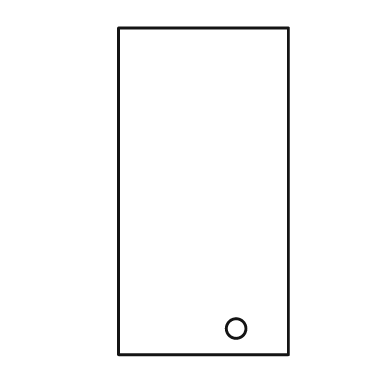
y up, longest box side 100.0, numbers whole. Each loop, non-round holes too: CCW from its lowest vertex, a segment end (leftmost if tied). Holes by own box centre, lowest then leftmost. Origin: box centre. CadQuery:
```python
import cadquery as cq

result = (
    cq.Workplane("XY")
    .moveTo(-26.0, -50.0)
    .lineTo(26.0, -50.0)
    .lineTo(26.0, 50.0)
    .lineTo(-26.0, 50.0)
    .close()
    .moveTo(10.0, -42.0)
    .circle(3.0)
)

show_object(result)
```